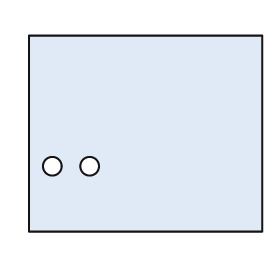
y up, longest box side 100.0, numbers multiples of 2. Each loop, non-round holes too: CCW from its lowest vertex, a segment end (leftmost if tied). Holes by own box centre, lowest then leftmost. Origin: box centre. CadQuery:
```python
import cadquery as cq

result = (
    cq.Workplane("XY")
    .moveTo(-50.0, -42.0)
    .lineTo(50.0, -42.0)
    .lineTo(50.0, 42.0)
    .lineTo(-50.0, 42.0)
    .close()
    .moveTo(-40.0, -14.0)
    .circle(4.0)
    .moveTo(-24.0, -14.0)
    .circle(4.0)
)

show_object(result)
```